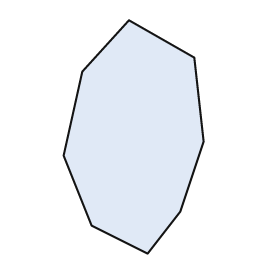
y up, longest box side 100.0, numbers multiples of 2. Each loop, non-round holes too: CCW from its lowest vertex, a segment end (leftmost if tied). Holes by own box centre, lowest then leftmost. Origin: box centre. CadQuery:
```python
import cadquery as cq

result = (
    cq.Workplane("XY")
    .moveTo(6.0, -50.0)
    .lineTo(20.0, -32.0)
    .lineTo(30.0, -2.0)
    .lineTo(26.0, 34.0)
    .lineTo(-2.0, 50.0)
    .lineTo(-22.0, 28.0)
    .lineTo(-30.0, -8.0)
    .lineTo(-18.0, -38.0)
    .close()
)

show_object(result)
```